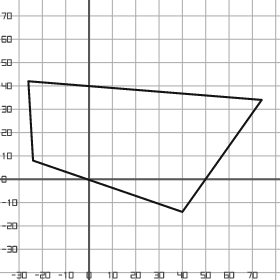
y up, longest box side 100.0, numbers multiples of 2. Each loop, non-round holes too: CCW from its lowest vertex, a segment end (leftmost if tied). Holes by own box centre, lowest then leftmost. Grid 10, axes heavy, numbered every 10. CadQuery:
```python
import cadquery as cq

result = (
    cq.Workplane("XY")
    .moveTo(40.0, -14.0)
    .lineTo(74.0, 34.0)
    .lineTo(-26.0, 42.0)
    .lineTo(-24.0, 8.0)
    .close()
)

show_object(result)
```